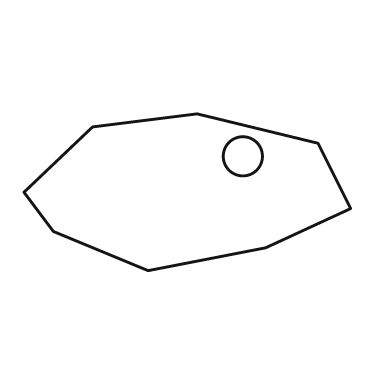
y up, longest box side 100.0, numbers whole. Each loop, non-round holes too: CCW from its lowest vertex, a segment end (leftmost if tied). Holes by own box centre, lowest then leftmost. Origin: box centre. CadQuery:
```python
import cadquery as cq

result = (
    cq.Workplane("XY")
    .moveTo(-12.0, -24.0)
    .lineTo(24.0, -17.0)
    .lineTo(50.0, -5.0)
    .lineTo(40.0, 15.0)
    .lineTo(3.0, 24.0)
    .lineTo(-29.0, 20.0)
    .lineTo(-50.0, 0.0)
    .lineTo(-41.0, -12.0)
    .close()
    .moveTo(17.0, 11.0)
    .circle(6.0)
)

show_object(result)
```